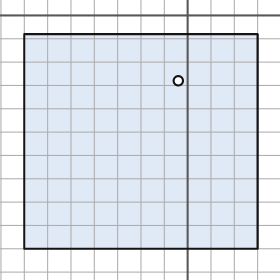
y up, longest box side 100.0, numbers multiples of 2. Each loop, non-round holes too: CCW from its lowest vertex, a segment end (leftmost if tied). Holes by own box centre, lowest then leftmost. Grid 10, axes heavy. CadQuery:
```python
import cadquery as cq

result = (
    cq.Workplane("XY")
    .moveTo(-70.0, -100.0)
    .lineTo(30.0, -100.0)
    .lineTo(30.0, -8.0)
    .lineTo(-70.0, -8.0)
    .close()
    .moveTo(-4.0, -28.0)
    .circle(2.0)
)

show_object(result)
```